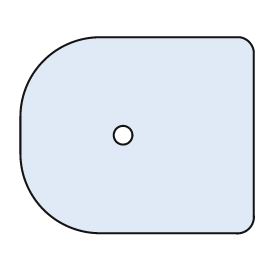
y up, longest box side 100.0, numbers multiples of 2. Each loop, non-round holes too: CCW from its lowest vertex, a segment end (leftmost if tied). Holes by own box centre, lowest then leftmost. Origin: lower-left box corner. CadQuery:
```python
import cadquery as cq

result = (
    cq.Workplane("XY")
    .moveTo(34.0, 0.0)
    .lineTo(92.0, 0.0)
    .threePointArc((98.0, 2.0), (100.0, 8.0))
    .lineTo(100.0, 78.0)
    .threePointArc((98.0, 82.0), (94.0, 84.0))
    .lineTo(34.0, 84.0)
    .threePointArc((10.0, 74.0), (0.0, 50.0))
    .lineTo(0.0, 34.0)
    .threePointArc((10.0, 10.0), (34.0, 0.0))
    .close()
    .moveTo(44.0, 42.0)
    .circle(4.0)
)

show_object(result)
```